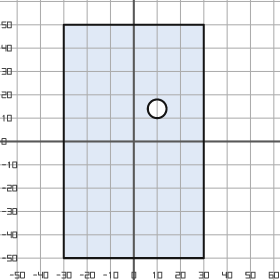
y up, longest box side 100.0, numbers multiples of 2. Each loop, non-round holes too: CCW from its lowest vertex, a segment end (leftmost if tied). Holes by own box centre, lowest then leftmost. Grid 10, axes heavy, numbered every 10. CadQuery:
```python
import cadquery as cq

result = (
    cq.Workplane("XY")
    .moveTo(-30.0, -50.0)
    .lineTo(30.0, -50.0)
    .lineTo(30.0, 50.0)
    .lineTo(-30.0, 50.0)
    .close()
    .moveTo(10.0, 14.0)
    .circle(4.0)
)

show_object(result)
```